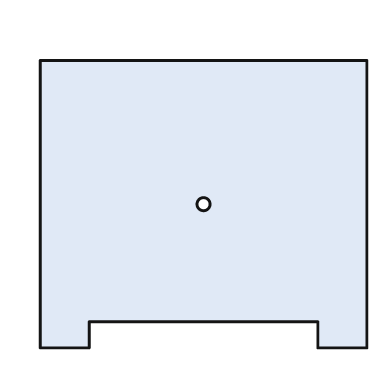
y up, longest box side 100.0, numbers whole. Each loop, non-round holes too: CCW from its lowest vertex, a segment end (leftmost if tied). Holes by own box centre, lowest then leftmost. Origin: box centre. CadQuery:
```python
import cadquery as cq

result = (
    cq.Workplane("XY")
    .moveTo(-50.0, -44.0)
    .lineTo(-35.0, -44.0)
    .lineTo(-35.0, -36.0)
    .lineTo(35.0, -36.0)
    .lineTo(35.0, -44.0)
    .lineTo(50.0, -44.0)
    .lineTo(50.0, 44.0)
    .lineTo(-50.0, 44.0)
    .close()
    .moveTo(0.0, 0.0)
    .circle(2.0)
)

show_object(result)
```